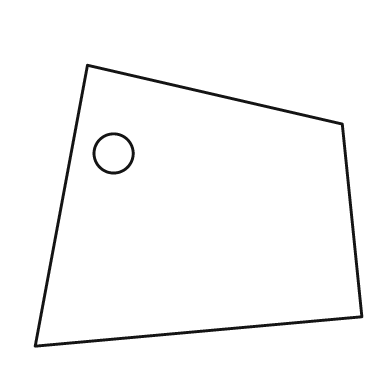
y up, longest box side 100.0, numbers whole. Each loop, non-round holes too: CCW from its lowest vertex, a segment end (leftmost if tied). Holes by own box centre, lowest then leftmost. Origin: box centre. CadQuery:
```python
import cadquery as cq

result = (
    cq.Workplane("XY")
    .moveTo(-50.0, -43.0)
    .lineTo(50.0, -34.0)
    .lineTo(44.0, 25.0)
    .lineTo(-34.0, 43.0)
    .close()
    .moveTo(-26.0, 16.0)
    .circle(6.0)
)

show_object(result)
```